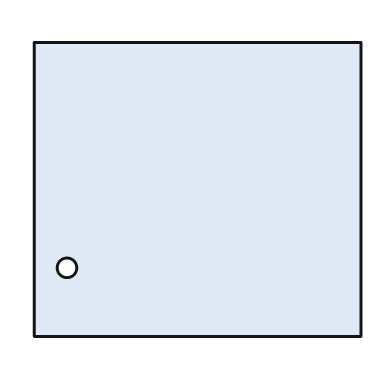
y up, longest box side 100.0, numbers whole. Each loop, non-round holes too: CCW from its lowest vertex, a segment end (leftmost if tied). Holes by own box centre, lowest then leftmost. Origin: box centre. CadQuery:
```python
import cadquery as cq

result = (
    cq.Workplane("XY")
    .moveTo(-50.0, -45.0)
    .lineTo(50.0, -45.0)
    .lineTo(50.0, 45.0)
    .lineTo(-50.0, 45.0)
    .close()
    .moveTo(-40.0, -24.0)
    .circle(3.0)
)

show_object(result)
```